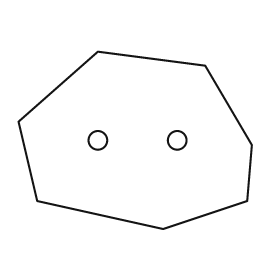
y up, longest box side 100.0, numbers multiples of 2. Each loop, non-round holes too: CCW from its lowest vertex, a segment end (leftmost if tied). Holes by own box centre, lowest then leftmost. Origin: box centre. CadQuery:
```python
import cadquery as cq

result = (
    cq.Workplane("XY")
    .moveTo(12.0, -38.0)
    .lineTo(48.0, -26.0)
    .lineTo(50.0, -2.0)
    .lineTo(30.0, 32.0)
    .lineTo(-16.0, 38.0)
    .lineTo(-50.0, 8.0)
    .lineTo(-42.0, -26.0)
    .close()
    .moveTo(-16.0, 0.0)
    .circle(4.0)
    .moveTo(18.0, 0.0)
    .circle(4.0)
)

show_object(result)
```